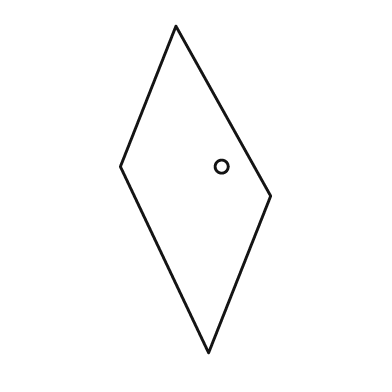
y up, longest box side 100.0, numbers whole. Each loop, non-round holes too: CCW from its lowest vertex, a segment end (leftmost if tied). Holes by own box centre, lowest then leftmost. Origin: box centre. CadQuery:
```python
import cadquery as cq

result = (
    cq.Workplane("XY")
    .moveTo(4.0, -50.0)
    .lineTo(23.0, -2.0)
    .lineTo(-6.0, 50.0)
    .lineTo(-23.0, 7.0)
    .close()
    .moveTo(8.0, 7.0)
    .circle(2.0)
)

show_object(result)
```